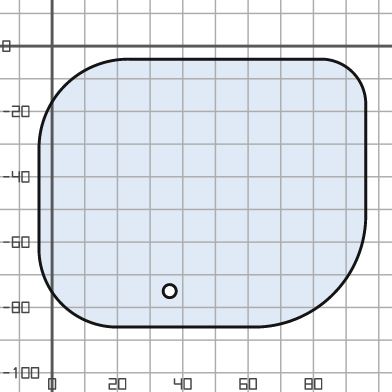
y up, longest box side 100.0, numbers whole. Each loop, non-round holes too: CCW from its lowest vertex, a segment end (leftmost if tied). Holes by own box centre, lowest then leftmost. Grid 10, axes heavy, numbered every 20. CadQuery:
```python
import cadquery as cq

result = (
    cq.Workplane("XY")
    .moveTo(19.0, -86.0)
    .lineTo(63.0, -86.0)
    .threePointArc((86.0, -76.0), (96.0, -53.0))
    .lineTo(96.0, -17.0)
    .threePointArc((92.0, -8.0), (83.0, -4.0))
    .lineTo(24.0, -4.0)
    .threePointArc((4.0, -12.0), (-4.0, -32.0))
    .lineTo(-4.0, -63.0)
    .threePointArc((3.0, -79.0), (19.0, -86.0))
    .close()
    .moveTo(36.0, -75.0)
    .circle(2.0)
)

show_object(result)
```